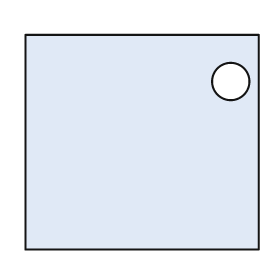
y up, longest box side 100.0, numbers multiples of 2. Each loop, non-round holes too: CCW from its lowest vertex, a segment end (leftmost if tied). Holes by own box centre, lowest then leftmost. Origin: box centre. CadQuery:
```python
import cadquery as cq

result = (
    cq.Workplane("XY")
    .moveTo(-50.0, -46.0)
    .lineTo(50.0, -46.0)
    .lineTo(50.0, 46.0)
    .lineTo(-50.0, 46.0)
    .close()
    .moveTo(38.0, 26.0)
    .circle(8.0)
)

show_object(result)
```